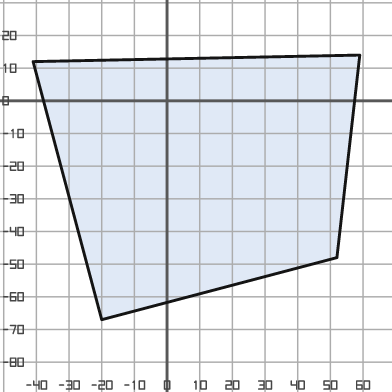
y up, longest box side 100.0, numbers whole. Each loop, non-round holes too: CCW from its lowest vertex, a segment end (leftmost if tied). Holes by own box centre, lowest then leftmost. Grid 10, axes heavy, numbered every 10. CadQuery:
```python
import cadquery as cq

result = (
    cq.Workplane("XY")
    .moveTo(-20.0, -67.0)
    .lineTo(52.0, -48.0)
    .lineTo(59.0, 14.0)
    .lineTo(-41.0, 12.0)
    .close()
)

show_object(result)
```